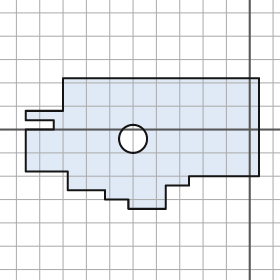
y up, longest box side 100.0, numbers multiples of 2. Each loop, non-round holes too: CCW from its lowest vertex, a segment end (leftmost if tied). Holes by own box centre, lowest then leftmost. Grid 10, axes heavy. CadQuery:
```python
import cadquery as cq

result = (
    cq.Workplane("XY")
    .moveTo(-52.0, -34.0)
    .lineTo(-36.0, -34.0)
    .lineTo(-36.0, -24.0)
    .lineTo(-26.0, -24.0)
    .lineTo(-26.0, -20.0)
    .lineTo(4.0, -20.0)
    .lineTo(4.0, 22.0)
    .lineTo(-80.0, 22.0)
    .lineTo(-80.0, 8.0)
    .lineTo(-96.0, 8.0)
    .lineTo(-96.0, 4.0)
    .lineTo(-84.0, 4.0)
    .lineTo(-84.0, 0.0)
    .lineTo(-96.0, 0.0)
    .lineTo(-96.0, -18.0)
    .lineTo(-78.0, -18.0)
    .lineTo(-78.0, -26.0)
    .lineTo(-62.0, -26.0)
    .lineTo(-62.0, -30.0)
    .lineTo(-52.0, -30.0)
    .close()
    .moveTo(-50.0, -4.0)
    .circle(6.0)
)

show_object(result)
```